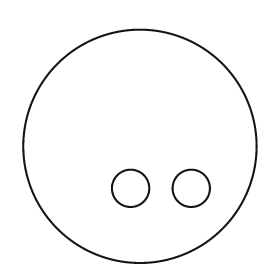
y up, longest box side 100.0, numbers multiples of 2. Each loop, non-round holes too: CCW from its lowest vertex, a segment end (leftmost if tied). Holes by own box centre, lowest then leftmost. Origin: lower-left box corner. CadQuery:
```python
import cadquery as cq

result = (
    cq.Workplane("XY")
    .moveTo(50.0, 50.0)
    .circle(50.0)
    .moveTo(46.0, 32.0)
    .circle(8.0)
    .moveTo(72.0, 32.0)
    .circle(8.0)
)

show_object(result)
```